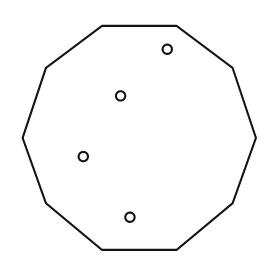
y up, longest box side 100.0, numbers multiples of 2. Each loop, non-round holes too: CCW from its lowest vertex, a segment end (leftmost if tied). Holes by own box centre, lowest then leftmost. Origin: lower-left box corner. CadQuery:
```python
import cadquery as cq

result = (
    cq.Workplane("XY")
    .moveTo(34.0, 0.0)
    .lineTo(66.0, 0.0)
    .lineTo(90.0, 20.0)
    .lineTo(100.0, 48.0)
    .lineTo(90.0, 78.0)
    .lineTo(66.0, 96.0)
    .lineTo(34.0, 96.0)
    .lineTo(10.0, 78.0)
    .lineTo(0.0, 48.0)
    .lineTo(10.0, 20.0)
    .close()
    .moveTo(46.0, 14.0)
    .circle(2.0)
    .moveTo(26.0, 40.0)
    .circle(2.0)
    .moveTo(42.0, 66.0)
    .circle(2.0)
    .moveTo(62.0, 86.0)
    .circle(2.0)
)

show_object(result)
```